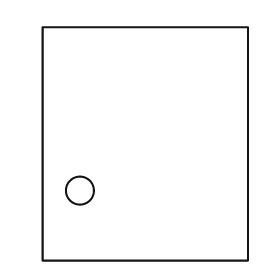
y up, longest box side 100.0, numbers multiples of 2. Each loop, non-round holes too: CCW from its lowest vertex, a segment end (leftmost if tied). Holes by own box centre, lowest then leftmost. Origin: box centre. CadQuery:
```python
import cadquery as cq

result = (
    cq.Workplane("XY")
    .moveTo(-44.0, -50.0)
    .lineTo(44.0, -50.0)
    .lineTo(44.0, 50.0)
    .lineTo(-44.0, 50.0)
    .close()
    .moveTo(-28.0, -20.0)
    .circle(6.0)
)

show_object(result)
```